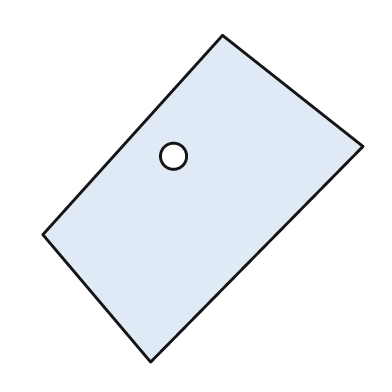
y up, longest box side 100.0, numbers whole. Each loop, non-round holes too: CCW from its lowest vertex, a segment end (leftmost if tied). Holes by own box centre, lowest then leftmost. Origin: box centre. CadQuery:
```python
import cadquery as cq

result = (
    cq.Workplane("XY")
    .moveTo(-16.0, -50.0)
    .lineTo(49.0, 16.0)
    .lineTo(6.0, 50.0)
    .lineTo(-49.0, -11.0)
    .close()
    .moveTo(-9.0, 13.0)
    .circle(4.0)
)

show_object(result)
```